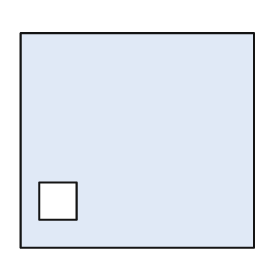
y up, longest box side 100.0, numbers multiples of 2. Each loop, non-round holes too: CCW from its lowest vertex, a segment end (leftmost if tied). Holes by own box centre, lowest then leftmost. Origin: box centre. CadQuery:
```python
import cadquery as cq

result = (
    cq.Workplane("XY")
    .moveTo(-50.0, -46.0)
    .lineTo(50.0, -46.0)
    .lineTo(50.0, 46.0)
    .lineTo(-50.0, 46.0)
    .close()
    .moveTo(-42.0, -34.0)
    .lineTo(-26.0, -34.0)
    .lineTo(-26.0, -18.0)
    .lineTo(-42.0, -18.0)
    .close()
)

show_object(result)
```